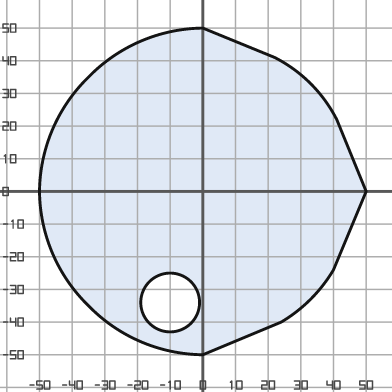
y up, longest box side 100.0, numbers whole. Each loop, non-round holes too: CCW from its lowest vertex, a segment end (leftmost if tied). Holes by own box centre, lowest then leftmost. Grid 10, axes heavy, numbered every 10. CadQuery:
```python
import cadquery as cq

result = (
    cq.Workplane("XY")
    .moveTo(0.0, -50.0)
    .lineTo(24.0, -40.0)
    .threePointArc((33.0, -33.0), (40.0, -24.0))
    .lineTo(50.0, 0.0)
    .lineTo(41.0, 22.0)
    .threePointArc((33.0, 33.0), (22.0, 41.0))
    .lineTo(0.0, 50.0)
    .threePointArc((-19.0, 46.0), (-35.0, 35.0))
    .threePointArc((-46.0, 19.0), (-50.0, 0.0))
    .threePointArc((-46.0, -19.0), (-35.0, -35.0))
    .threePointArc((-19.0, -46.0), (0.0, -50.0))
    .close()
    .moveTo(-10.0, -34.0)
    .circle(9.0)
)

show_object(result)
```